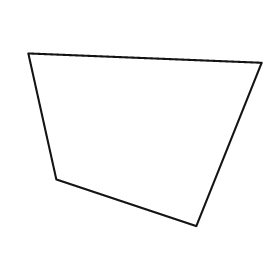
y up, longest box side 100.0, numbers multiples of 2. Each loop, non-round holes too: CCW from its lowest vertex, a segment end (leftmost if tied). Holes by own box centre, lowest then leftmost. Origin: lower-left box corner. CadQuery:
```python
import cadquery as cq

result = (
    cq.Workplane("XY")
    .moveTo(72.0, 0.0)
    .lineTo(100.0, 70.0)
    .lineTo(0.0, 74.0)
    .lineTo(12.0, 20.0)
    .close()
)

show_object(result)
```